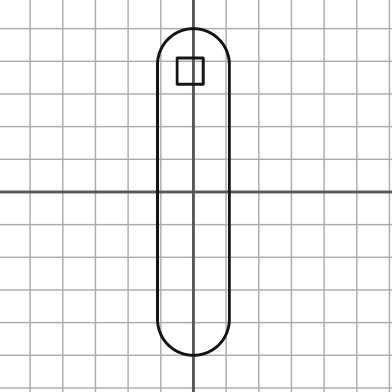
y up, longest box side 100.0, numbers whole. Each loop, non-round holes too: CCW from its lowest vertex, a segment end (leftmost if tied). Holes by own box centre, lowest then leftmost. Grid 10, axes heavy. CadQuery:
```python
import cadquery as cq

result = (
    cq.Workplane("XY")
    .moveTo(-11.0, -39.0)
    .threePointArc((0.0, -50.0), (11.0, -39.0))
    .lineTo(11.0, 39.0)
    .threePointArc((0.0, 50.0), (-11.0, 39.0))
    .close()
    .moveTo(-5.0, 33.0)
    .lineTo(3.0, 33.0)
    .lineTo(3.0, 41.0)
    .lineTo(-5.0, 41.0)
    .close()
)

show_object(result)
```